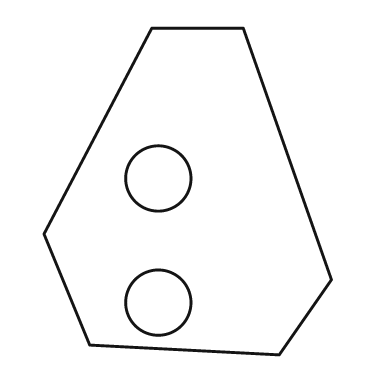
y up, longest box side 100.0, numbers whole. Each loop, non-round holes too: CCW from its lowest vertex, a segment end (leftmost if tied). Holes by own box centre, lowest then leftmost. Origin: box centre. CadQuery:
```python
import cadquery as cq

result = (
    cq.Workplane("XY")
    .moveTo(28.0, -50.0)
    .lineTo(44.0, -27.0)
    .lineTo(17.0, 50.0)
    .lineTo(-11.0, 50.0)
    .lineTo(-44.0, -13.0)
    .lineTo(-30.0, -47.0)
    .close()
    .moveTo(-9.0, -34.0)
    .circle(10.0)
    .moveTo(-9.0, 4.0)
    .circle(10.0)
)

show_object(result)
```